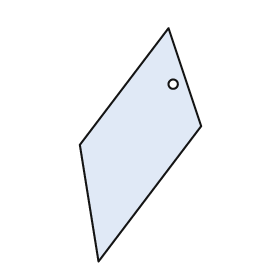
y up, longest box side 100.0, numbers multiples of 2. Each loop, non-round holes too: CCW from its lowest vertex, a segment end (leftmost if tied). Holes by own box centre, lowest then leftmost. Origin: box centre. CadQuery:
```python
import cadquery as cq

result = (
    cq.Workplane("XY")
    .moveTo(-18.0, -50.0)
    .lineTo(26.0, 8.0)
    .lineTo(12.0, 50.0)
    .lineTo(-26.0, 0.0)
    .close()
    .moveTo(14.0, 26.0)
    .circle(2.0)
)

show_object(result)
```